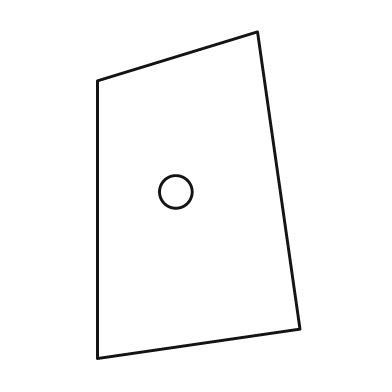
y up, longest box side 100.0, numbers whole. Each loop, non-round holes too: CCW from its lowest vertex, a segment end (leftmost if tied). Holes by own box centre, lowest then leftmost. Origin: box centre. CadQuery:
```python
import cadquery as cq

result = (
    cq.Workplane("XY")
    .moveTo(-31.0, -50.0)
    .lineTo(31.0, -41.0)
    .lineTo(18.0, 50.0)
    .lineTo(-31.0, 35.0)
    .close()
    .moveTo(-7.0, 1.0)
    .circle(5.0)
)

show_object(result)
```